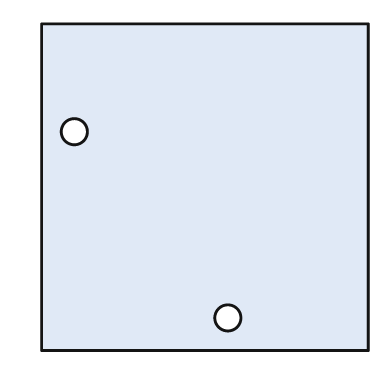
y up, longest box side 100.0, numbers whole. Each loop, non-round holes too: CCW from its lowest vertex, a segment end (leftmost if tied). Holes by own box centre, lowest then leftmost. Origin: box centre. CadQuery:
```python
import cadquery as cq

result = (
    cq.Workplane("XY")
    .moveTo(-50.0, -50.0)
    .lineTo(50.0, -50.0)
    .lineTo(50.0, 50.0)
    .lineTo(-50.0, 50.0)
    .close()
    .moveTo(7.0, -40.0)
    .circle(4.0)
    .moveTo(-40.0, 17.0)
    .circle(4.0)
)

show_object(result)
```